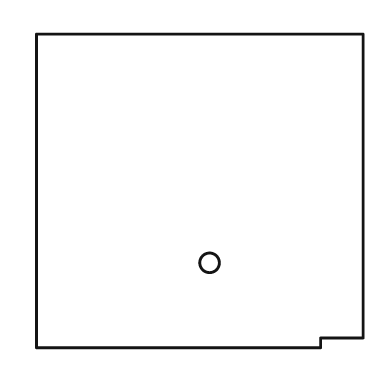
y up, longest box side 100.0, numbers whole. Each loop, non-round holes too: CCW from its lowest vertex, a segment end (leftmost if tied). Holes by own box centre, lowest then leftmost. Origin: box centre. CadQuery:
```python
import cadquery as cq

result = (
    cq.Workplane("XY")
    .moveTo(-50.0, -48.0)
    .lineTo(37.0, -48.0)
    .lineTo(37.0, -45.0)
    .lineTo(50.0, -45.0)
    .lineTo(50.0, 48.0)
    .lineTo(-50.0, 48.0)
    .close()
    .moveTo(3.0, -22.0)
    .circle(3.0)
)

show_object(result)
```